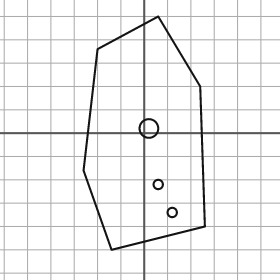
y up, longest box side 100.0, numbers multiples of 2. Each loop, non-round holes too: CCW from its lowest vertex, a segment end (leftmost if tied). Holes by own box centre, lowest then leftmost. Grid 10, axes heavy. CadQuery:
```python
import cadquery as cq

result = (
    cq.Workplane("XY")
    .moveTo(-14.0, -50.0)
    .lineTo(26.0, -40.0)
    .lineTo(24.0, 20.0)
    .lineTo(6.0, 50.0)
    .lineTo(-20.0, 36.0)
    .lineTo(-26.0, -16.0)
    .close()
    .moveTo(12.0, -34.0)
    .circle(2.0)
    .moveTo(6.0, -22.0)
    .circle(2.0)
    .moveTo(2.0, 2.0)
    .circle(4.0)
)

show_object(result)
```